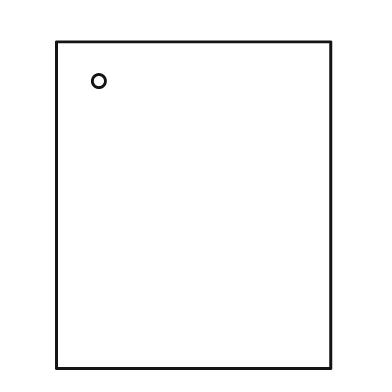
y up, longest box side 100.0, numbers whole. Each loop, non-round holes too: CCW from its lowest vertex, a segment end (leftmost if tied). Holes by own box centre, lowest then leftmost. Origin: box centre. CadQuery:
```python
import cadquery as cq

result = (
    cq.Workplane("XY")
    .moveTo(-42.0, -50.0)
    .lineTo(42.0, -50.0)
    .lineTo(42.0, 50.0)
    .lineTo(-42.0, 50.0)
    .close()
    .moveTo(-29.0, 38.0)
    .circle(2.0)
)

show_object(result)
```